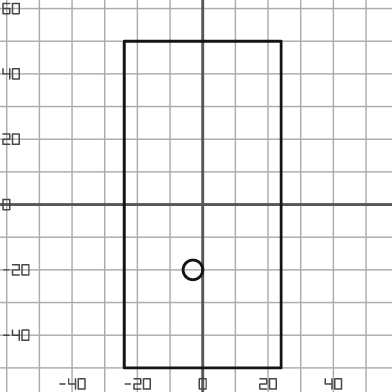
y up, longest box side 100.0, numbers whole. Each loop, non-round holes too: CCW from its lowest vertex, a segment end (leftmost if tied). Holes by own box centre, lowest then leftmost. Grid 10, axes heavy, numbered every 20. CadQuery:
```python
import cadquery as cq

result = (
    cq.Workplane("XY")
    .moveTo(-24.0, -50.0)
    .lineTo(24.0, -50.0)
    .lineTo(24.0, 50.0)
    .lineTo(-24.0, 50.0)
    .close()
    .moveTo(-3.0, -20.0)
    .circle(3.0)
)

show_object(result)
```